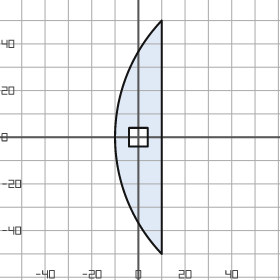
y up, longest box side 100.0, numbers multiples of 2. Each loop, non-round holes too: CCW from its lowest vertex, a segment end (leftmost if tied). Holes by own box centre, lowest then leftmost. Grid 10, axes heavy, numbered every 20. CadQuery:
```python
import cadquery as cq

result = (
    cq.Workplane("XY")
    .moveTo(10.0, -50.0)
    .lineTo(10.0, 50.0)
    .threePointArc((-10.0, 0.0), (10.0, -50.0))
    .close()
    .moveTo(-4.0, -4.0)
    .lineTo(4.0, -4.0)
    .lineTo(4.0, 4.0)
    .lineTo(-4.0, 4.0)
    .close()
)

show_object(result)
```